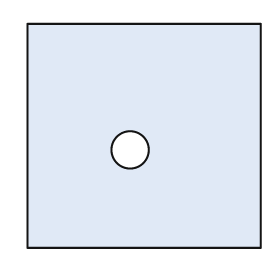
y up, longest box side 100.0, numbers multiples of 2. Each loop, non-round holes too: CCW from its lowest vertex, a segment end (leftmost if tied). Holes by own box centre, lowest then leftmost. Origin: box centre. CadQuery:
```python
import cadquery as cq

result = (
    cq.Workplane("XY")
    .moveTo(-50.0, -48.0)
    .lineTo(50.0, -48.0)
    .lineTo(50.0, 48.0)
    .lineTo(-50.0, 48.0)
    .close()
    .moveTo(-6.0, -6.0)
    .circle(8.0)
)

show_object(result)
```